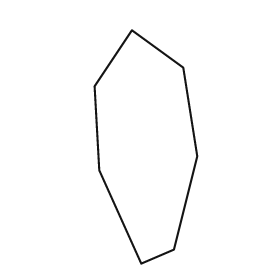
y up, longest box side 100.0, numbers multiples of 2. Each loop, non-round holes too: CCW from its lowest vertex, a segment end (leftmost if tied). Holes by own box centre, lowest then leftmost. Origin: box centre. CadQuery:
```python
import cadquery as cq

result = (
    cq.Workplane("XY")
    .moveTo(-2.0, -50.0)
    .lineTo(12.0, -44.0)
    .lineTo(22.0, -4.0)
    .lineTo(16.0, 34.0)
    .lineTo(-6.0, 50.0)
    .lineTo(-22.0, 26.0)
    .lineTo(-20.0, -10.0)
    .close()
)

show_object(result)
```